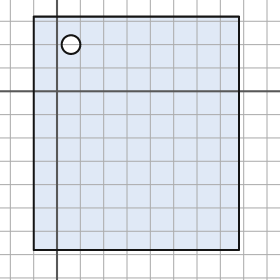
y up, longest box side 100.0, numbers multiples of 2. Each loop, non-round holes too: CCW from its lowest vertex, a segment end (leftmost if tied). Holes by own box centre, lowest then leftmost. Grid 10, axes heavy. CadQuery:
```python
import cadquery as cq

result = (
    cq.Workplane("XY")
    .moveTo(-10.0, -68.0)
    .lineTo(78.0, -68.0)
    .lineTo(78.0, 32.0)
    .lineTo(-10.0, 32.0)
    .close()
    .moveTo(6.0, 20.0)
    .circle(4.0)
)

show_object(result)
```